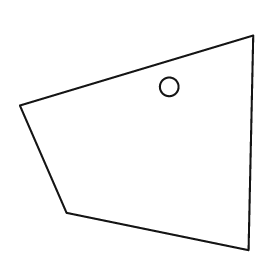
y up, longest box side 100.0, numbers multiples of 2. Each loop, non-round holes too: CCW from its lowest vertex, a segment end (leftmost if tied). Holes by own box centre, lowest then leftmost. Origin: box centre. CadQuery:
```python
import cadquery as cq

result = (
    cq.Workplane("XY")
    .moveTo(48.0, -46.0)
    .lineTo(50.0, 46.0)
    .lineTo(-50.0, 16.0)
    .lineTo(-30.0, -30.0)
    .close()
    .moveTo(14.0, 24.0)
    .circle(4.0)
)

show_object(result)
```